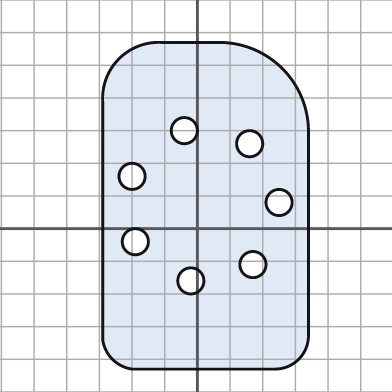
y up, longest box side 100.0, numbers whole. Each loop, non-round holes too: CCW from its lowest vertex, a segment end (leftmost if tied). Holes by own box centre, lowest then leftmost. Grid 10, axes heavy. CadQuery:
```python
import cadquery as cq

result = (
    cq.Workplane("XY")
    .moveTo(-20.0, -43.0)
    .lineTo(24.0, -43.0)
    .threePointArc((31.0, -40.0), (34.0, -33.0))
    .lineTo(34.0, 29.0)
    .threePointArc((26.0, 49.0), (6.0, 57.0))
    .lineTo(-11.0, 57.0)
    .threePointArc((-24.0, 52.0), (-29.0, 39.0))
    .lineTo(-29.0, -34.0)
    .threePointArc((-26.0, -40.0), (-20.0, -43.0))
    .close()
    .moveTo(-2.0, -16.0)
    .circle(4.0)
    .moveTo(17.0, -11.0)
    .circle(4.0)
    .moveTo(-19.0, -4.0)
    .circle(4.0)
    .moveTo(25.0, 8.0)
    .circle(4.0)
    .moveTo(-20.0, 16.0)
    .circle(4.0)
    .moveTo(16.0, 26.0)
    .circle(4.0)
    .moveTo(-4.0, 30.0)
    .circle(4.0)
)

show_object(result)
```